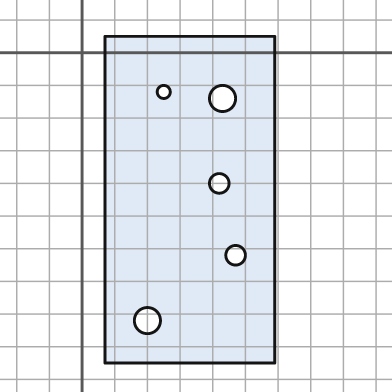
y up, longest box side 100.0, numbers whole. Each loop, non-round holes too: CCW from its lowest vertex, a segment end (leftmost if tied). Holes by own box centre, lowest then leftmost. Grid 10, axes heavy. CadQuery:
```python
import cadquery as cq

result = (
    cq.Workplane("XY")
    .moveTo(7.0, -95.0)
    .lineTo(59.0, -95.0)
    .lineTo(59.0, 5.0)
    .lineTo(7.0, 5.0)
    .close()
    .moveTo(20.0, -82.0)
    .circle(4.0)
    .moveTo(47.0, -62.0)
    .circle(3.0)
    .moveTo(42.0, -40.0)
    .circle(3.0)
    .moveTo(43.0, -14.0)
    .circle(4.0)
    .moveTo(25.0, -12.0)
    .circle(2.0)
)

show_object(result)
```